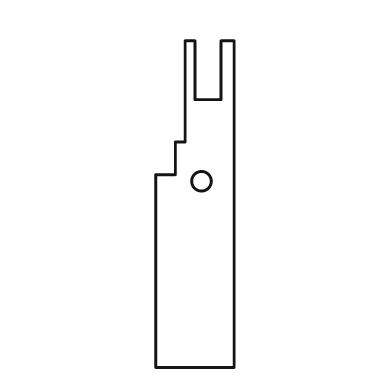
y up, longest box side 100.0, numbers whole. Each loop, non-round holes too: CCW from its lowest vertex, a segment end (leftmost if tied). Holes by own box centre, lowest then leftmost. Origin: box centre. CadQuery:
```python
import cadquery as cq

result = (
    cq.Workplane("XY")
    .moveTo(-12.0, -50.0)
    .lineTo(12.0, -50.0)
    .lineTo(12.0, 50.0)
    .lineTo(8.0, 50.0)
    .lineTo(8.0, 32.0)
    .lineTo(0.0, 32.0)
    .lineTo(0.0, 50.0)
    .lineTo(-3.0, 50.0)
    .lineTo(-3.0, 19.0)
    .lineTo(-6.0, 19.0)
    .lineTo(-6.0, 9.0)
    .lineTo(-12.0, 9.0)
    .close()
    .moveTo(2.0, 7.0)
    .circle(3.0)
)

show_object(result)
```